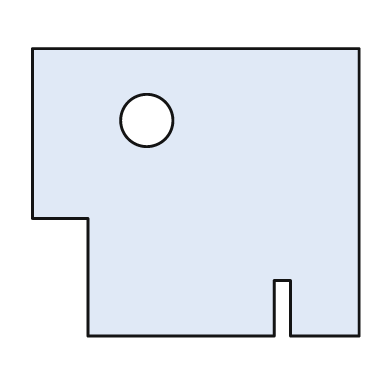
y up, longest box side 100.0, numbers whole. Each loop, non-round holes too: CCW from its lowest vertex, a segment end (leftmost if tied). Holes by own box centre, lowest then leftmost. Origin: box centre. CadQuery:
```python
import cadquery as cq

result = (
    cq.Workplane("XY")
    .moveTo(-33.0, -44.0)
    .lineTo(24.0, -44.0)
    .lineTo(24.0, -27.0)
    .lineTo(29.0, -27.0)
    .lineTo(29.0, -44.0)
    .lineTo(50.0, -44.0)
    .lineTo(50.0, 44.0)
    .lineTo(-50.0, 44.0)
    .lineTo(-50.0, -8.0)
    .lineTo(-33.0, -8.0)
    .close()
    .moveTo(-15.0, 22.0)
    .circle(8.0)
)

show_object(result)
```